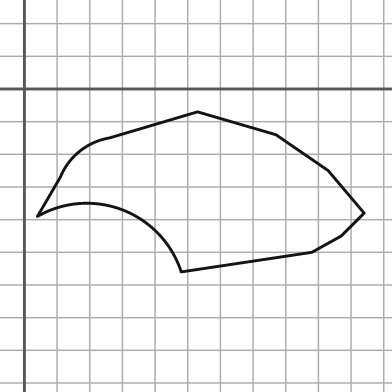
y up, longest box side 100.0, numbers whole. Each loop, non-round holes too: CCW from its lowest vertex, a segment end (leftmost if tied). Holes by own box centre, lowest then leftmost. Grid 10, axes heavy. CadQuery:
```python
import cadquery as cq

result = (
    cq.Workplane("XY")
    .moveTo(48.0, -56.0)
    .lineTo(88.0, -50.0)
    .lineTo(97.0, -45.0)
    .lineTo(104.0, -38.0)
    .lineTo(93.0, -25.0)
    .lineTo(77.0, -14.0)
    .lineTo(53.0, -7.0)
    .lineTo(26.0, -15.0)
    .threePointArc((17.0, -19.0), (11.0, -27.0))
    .lineTo(4.0, -39.0)
    .threePointArc((30.0, -37.0), (48.0, -56.0))
    .close()
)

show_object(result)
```